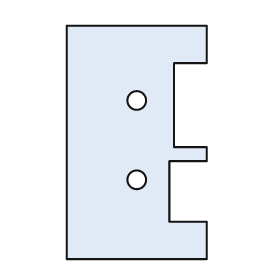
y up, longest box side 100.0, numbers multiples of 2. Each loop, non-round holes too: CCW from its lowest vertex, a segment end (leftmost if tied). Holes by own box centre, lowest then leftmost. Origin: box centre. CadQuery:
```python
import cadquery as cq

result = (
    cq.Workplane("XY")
    .moveTo(-30.0, -50.0)
    .lineTo(30.0, -50.0)
    .lineTo(30.0, -34.0)
    .lineTo(14.0, -34.0)
    .lineTo(14.0, -8.0)
    .lineTo(30.0, -8.0)
    .lineTo(30.0, -2.0)
    .lineTo(16.0, -2.0)
    .lineTo(16.0, 34.0)
    .lineTo(30.0, 34.0)
    .lineTo(30.0, 50.0)
    .lineTo(-30.0, 50.0)
    .close()
    .moveTo(0.0, -16.0)
    .circle(4.0)
    .moveTo(0.0, 18.0)
    .circle(4.0)
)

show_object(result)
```